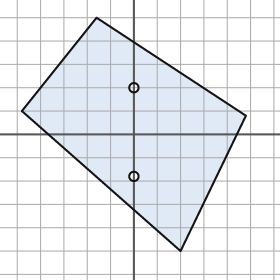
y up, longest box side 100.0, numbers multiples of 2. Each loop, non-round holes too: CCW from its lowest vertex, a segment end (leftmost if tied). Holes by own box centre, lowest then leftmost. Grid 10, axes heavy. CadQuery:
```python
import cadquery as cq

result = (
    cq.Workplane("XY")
    .moveTo(20.0, -50.0)
    .lineTo(48.0, 8.0)
    .lineTo(-16.0, 50.0)
    .lineTo(-48.0, 10.0)
    .close()
    .moveTo(0.0, -18.0)
    .circle(2.0)
    .moveTo(0.0, 20.0)
    .circle(2.0)
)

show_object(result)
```